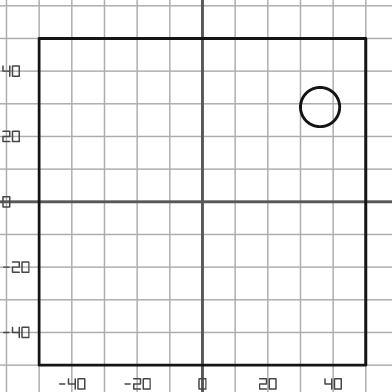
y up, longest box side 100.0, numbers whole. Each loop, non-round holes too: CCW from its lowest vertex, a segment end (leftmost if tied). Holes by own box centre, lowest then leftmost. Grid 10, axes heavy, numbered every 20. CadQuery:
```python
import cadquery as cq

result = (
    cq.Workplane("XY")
    .moveTo(-50.0, -50.0)
    .lineTo(50.0, -50.0)
    .lineTo(50.0, 50.0)
    .lineTo(-50.0, 50.0)
    .close()
    .moveTo(36.0, 29.0)
    .circle(6.0)
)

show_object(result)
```